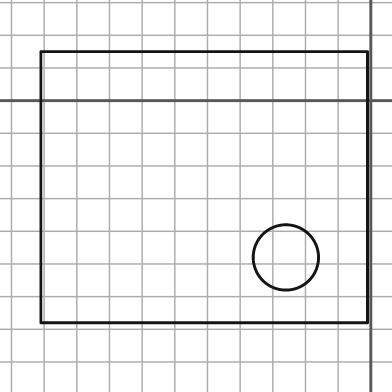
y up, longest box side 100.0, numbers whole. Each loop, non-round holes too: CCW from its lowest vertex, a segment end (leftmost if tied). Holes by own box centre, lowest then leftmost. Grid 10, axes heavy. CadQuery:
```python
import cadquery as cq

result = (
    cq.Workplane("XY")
    .moveTo(-101.0, -68.0)
    .lineTo(-1.0, -68.0)
    .lineTo(-1.0, 15.0)
    .lineTo(-101.0, 15.0)
    .close()
    .moveTo(-26.0, -48.0)
    .circle(10.0)
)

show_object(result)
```